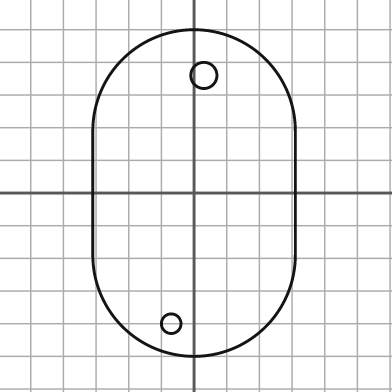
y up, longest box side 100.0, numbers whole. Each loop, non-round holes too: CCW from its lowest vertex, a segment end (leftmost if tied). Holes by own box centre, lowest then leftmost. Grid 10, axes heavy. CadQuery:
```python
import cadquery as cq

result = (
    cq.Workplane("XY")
    .moveTo(-31.0, -19.0)
    .threePointArc((0.0, -50.0), (31.0, -19.0))
    .lineTo(31.0, 19.0)
    .threePointArc((0.0, 50.0), (-31.0, 19.0))
    .close()
    .moveTo(-7.0, -40.0)
    .circle(3.0)
    .moveTo(3.0, 36.0)
    .circle(4.0)
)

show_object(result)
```